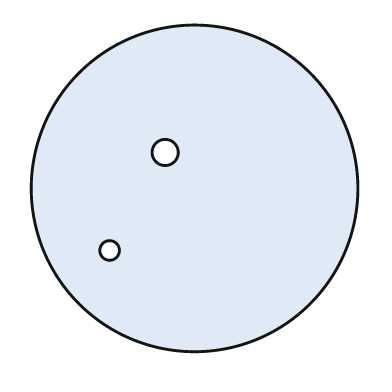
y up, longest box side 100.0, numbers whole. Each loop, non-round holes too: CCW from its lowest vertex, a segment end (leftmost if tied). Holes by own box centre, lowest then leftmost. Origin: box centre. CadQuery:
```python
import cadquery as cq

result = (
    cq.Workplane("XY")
    .moveTo(0.0, 0.0)
    .circle(50.0)
    .moveTo(-26.0, -19.0)
    .circle(3.0)
    .moveTo(-9.0, 11.0)
    .circle(4.0)
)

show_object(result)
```